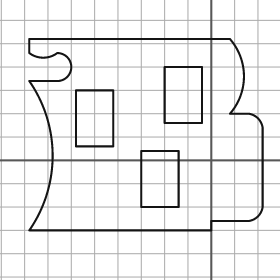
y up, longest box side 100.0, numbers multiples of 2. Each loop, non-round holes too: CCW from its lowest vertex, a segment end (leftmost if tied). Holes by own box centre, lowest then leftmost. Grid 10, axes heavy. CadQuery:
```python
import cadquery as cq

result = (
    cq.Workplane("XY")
    .moveTo(-78.0, -30.0)
    .lineTo(0.0, -30.0)
    .lineTo(0.0, -26.0)
    .lineTo(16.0, -26.0)
    .threePointArc((20.0, -24.0), (22.0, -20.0))
    .lineTo(22.0, 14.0)
    .threePointArc((20.0, 18.0), (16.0, 20.0))
    .lineTo(8.0, 20.0)
    .threePointArc((14.0, 36.0), (8.0, 52.0))
    .lineTo(-78.0, 52.0)
    .lineTo(-78.0, 46.0)
    .threePointArc((-72.0, 44.0), (-66.0, 46.0))
    .threePointArc((-60.0, 40.0), (-66.0, 34.0))
    .lineTo(-78.0, 34.0)
    .threePointArc((-68.0, 2.0), (-78.0, -30.0))
    .close()
    .moveTo(-30.0, -20.0)
    .lineTo(-14.0, -20.0)
    .lineTo(-14.0, 4.0)
    .lineTo(-30.0, 4.0)
    .close()
    .moveTo(-58.0, 6.0)
    .lineTo(-42.0, 6.0)
    .lineTo(-42.0, 30.0)
    .lineTo(-58.0, 30.0)
    .close()
    .moveTo(-20.0, 16.0)
    .lineTo(-4.0, 16.0)
    .lineTo(-4.0, 40.0)
    .lineTo(-20.0, 40.0)
    .close()
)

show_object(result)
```